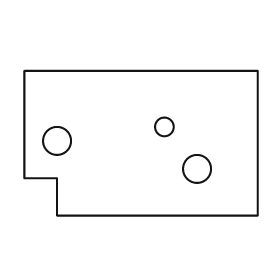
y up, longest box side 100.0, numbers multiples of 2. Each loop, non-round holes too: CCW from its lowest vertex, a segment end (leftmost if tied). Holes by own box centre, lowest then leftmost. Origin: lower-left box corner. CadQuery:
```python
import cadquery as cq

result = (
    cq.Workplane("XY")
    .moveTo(14.0, 0.0)
    .lineTo(100.0, 0.0)
    .lineTo(100.0, 62.0)
    .lineTo(0.0, 62.0)
    .lineTo(0.0, 16.0)
    .lineTo(14.0, 16.0)
    .close()
    .moveTo(74.0, 20.0)
    .circle(6.0)
    .moveTo(14.0, 32.0)
    .circle(6.0)
    .moveTo(60.0, 38.0)
    .circle(4.0)
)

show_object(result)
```